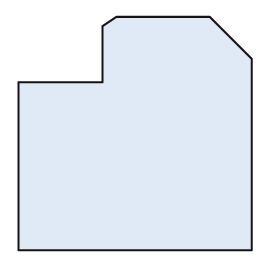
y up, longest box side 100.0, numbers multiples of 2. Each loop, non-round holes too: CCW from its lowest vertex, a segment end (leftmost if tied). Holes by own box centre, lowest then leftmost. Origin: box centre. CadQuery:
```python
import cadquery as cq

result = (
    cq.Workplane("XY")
    .moveTo(-50.0, -50.0)
    .lineTo(50.0, -50.0)
    .lineTo(50.0, 32.0)
    .lineTo(32.0, 50.0)
    .lineTo(-8.0, 50.0)
    .lineTo(-14.0, 46.0)
    .lineTo(-14.0, 22.0)
    .lineTo(-50.0, 22.0)
    .close()
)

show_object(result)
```